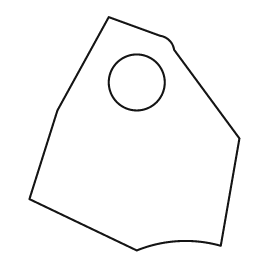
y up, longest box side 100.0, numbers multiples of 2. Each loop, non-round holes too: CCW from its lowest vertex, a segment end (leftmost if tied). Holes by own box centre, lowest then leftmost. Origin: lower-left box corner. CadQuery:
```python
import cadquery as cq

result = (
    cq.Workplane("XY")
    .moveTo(46.0, 0.0)
    .threePointArc((64.0, 4.0), (82.0, 2.0))
    .lineTo(90.0, 48.0)
    .lineTo(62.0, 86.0)
    .threePointArc((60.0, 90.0), (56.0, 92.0))
    .lineTo(34.0, 100.0)
    .lineTo(12.0, 60.0)
    .lineTo(0.0, 22.0)
    .close()
    .moveTo(46.0, 72.0)
    .circle(12.0)
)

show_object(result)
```